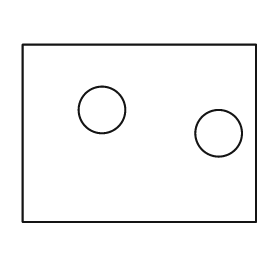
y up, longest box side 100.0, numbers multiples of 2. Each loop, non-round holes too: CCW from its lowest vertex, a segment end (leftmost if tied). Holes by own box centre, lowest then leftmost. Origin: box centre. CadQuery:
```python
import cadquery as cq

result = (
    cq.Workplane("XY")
    .moveTo(-50.0, -38.0)
    .lineTo(50.0, -38.0)
    .lineTo(50.0, 38.0)
    .lineTo(-50.0, 38.0)
    .close()
    .moveTo(34.0, 0.0)
    .circle(10.0)
    .moveTo(-16.0, 10.0)
    .circle(10.0)
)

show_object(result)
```